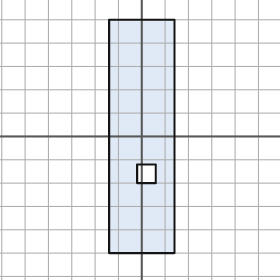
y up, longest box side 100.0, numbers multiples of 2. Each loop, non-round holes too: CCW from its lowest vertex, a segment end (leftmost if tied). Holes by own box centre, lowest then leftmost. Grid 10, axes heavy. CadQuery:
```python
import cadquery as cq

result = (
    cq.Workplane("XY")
    .moveTo(-14.0, -50.0)
    .lineTo(14.0, -50.0)
    .lineTo(14.0, 50.0)
    .lineTo(-14.0, 50.0)
    .close()
    .moveTo(-2.0, -20.0)
    .lineTo(6.0, -20.0)
    .lineTo(6.0, -12.0)
    .lineTo(-2.0, -12.0)
    .close()
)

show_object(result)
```